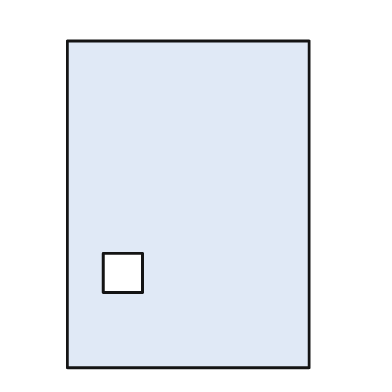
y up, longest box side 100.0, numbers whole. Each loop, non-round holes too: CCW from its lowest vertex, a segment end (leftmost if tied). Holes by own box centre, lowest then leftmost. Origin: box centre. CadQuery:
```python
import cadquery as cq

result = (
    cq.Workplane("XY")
    .moveTo(-37.0, -50.0)
    .lineTo(37.0, -50.0)
    .lineTo(37.0, 50.0)
    .lineTo(-37.0, 50.0)
    .close()
    .moveTo(-26.0, -27.0)
    .lineTo(-14.0, -27.0)
    .lineTo(-14.0, -15.0)
    .lineTo(-26.0, -15.0)
    .close()
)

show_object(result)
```